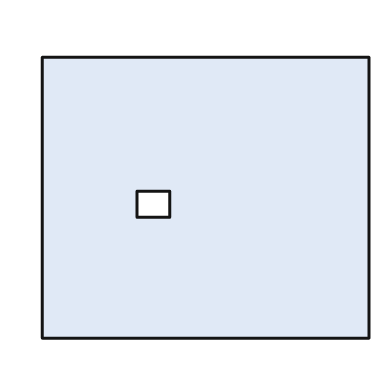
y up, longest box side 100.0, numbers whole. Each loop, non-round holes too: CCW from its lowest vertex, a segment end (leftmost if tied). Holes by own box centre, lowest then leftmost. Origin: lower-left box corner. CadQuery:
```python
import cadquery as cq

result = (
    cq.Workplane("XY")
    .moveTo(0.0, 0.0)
    .lineTo(100.0, 0.0)
    .lineTo(100.0, 86.0)
    .lineTo(0.0, 86.0)
    .close()
    .moveTo(29.0, 37.0)
    .lineTo(39.0, 37.0)
    .lineTo(39.0, 45.0)
    .lineTo(29.0, 45.0)
    .close()
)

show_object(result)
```